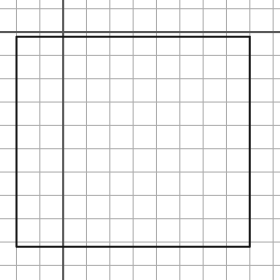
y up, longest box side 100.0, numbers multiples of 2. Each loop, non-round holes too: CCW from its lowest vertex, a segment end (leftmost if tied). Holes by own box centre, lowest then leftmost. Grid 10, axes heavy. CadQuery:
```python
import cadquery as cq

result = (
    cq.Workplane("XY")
    .moveTo(-20.0, -92.0)
    .lineTo(80.0, -92.0)
    .lineTo(80.0, -2.0)
    .lineTo(-20.0, -2.0)
    .close()
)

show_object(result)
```